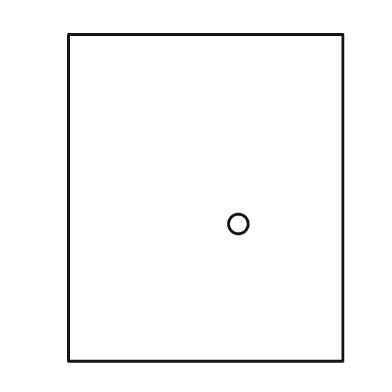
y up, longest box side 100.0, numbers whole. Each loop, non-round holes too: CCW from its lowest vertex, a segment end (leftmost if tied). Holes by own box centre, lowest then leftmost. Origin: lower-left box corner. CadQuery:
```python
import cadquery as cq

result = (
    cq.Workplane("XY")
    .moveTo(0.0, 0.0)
    .lineTo(84.0, 0.0)
    .lineTo(84.0, 100.0)
    .lineTo(0.0, 100.0)
    .close()
    .moveTo(52.0, 42.0)
    .circle(3.0)
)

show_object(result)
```